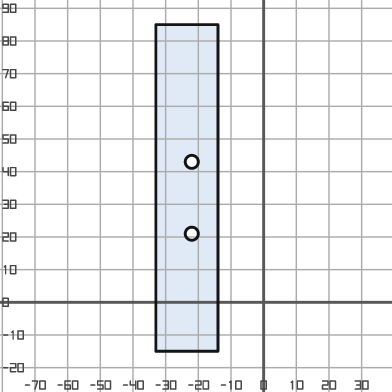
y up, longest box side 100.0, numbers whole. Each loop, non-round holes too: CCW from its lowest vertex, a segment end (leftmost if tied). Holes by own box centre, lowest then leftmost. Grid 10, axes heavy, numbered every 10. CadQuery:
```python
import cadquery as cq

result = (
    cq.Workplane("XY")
    .moveTo(-33.0, -15.0)
    .lineTo(-14.0, -15.0)
    .lineTo(-14.0, 85.0)
    .lineTo(-33.0, 85.0)
    .close()
    .moveTo(-22.0, 21.0)
    .circle(2.0)
    .moveTo(-22.0, 43.0)
    .circle(2.0)
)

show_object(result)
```